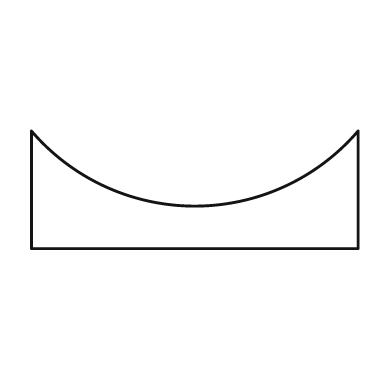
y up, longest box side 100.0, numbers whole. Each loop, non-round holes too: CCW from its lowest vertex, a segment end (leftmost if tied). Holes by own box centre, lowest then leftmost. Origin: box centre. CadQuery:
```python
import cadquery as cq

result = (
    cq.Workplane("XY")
    .moveTo(-50.0, -18.0)
    .lineTo(50.0, -18.0)
    .lineTo(50.0, 18.0)
    .threePointArc((0.0, -5.0), (-50.0, 18.0))
    .close()
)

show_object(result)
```